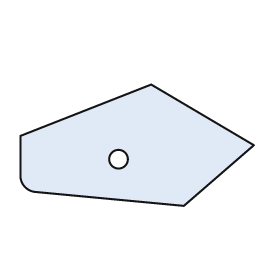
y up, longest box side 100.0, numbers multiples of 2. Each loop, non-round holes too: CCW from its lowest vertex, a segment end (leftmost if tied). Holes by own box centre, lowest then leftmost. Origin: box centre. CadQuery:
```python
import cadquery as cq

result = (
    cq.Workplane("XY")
    .moveTo(20.0, -26.0)
    .lineTo(50.0, 0.0)
    .lineTo(6.0, 26.0)
    .lineTo(-50.0, 4.0)
    .lineTo(-50.0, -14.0)
    .threePointArc((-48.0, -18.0), (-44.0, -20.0))
    .close()
    .moveTo(-8.0, -6.0)
    .circle(4.0)
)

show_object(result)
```